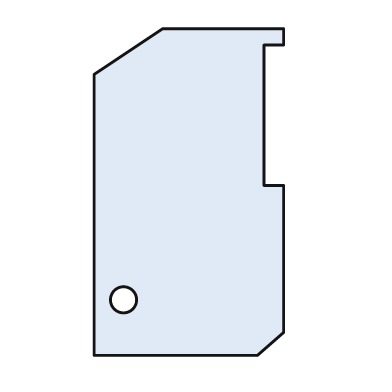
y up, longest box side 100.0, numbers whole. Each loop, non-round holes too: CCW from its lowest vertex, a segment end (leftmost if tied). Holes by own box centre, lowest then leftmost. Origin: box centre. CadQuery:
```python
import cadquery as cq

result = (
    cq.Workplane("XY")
    .moveTo(-29.0, -50.0)
    .lineTo(21.0, -50.0)
    .lineTo(29.0, -43.0)
    .lineTo(29.0, 2.0)
    .lineTo(23.0, 2.0)
    .lineTo(23.0, 45.0)
    .lineTo(29.0, 45.0)
    .lineTo(29.0, 50.0)
    .lineTo(-8.0, 50.0)
    .lineTo(-29.0, 36.0)
    .close()
    .moveTo(-20.0, -33.0)
    .circle(4.0)
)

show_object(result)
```